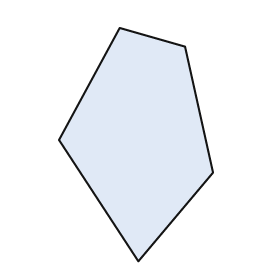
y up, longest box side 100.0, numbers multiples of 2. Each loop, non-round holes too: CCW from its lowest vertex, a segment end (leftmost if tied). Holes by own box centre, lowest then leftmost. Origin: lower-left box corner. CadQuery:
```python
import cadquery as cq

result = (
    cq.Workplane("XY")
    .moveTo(34.0, 0.0)
    .lineTo(66.0, 38.0)
    .lineTo(54.0, 92.0)
    .lineTo(26.0, 100.0)
    .lineTo(0.0, 52.0)
    .close()
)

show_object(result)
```